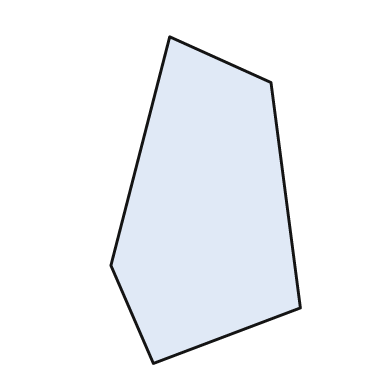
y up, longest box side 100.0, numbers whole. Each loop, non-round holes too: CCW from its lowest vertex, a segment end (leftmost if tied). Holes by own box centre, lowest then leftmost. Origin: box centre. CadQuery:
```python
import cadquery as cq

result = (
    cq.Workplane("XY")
    .moveTo(-16.0, -50.0)
    .lineTo(29.0, -33.0)
    .lineTo(20.0, 36.0)
    .lineTo(-11.0, 50.0)
    .lineTo(-29.0, -20.0)
    .close()
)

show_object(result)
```